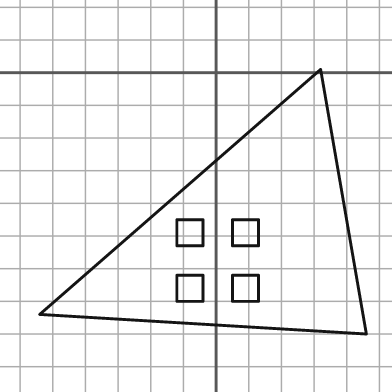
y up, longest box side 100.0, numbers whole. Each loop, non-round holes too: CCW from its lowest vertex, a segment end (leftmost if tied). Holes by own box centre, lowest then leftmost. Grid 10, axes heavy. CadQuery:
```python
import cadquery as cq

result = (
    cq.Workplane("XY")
    .moveTo(46.0, -80.0)
    .lineTo(32.0, 1.0)
    .lineTo(-54.0, -74.0)
    .close()
    .moveTo(-12.0, -70.0)
    .lineTo(-4.0, -70.0)
    .lineTo(-4.0, -62.0)
    .lineTo(-12.0, -62.0)
    .close()
    .moveTo(5.0, -70.0)
    .lineTo(13.0, -70.0)
    .lineTo(13.0, -62.0)
    .lineTo(5.0, -62.0)
    .close()
    .moveTo(-12.0, -53.0)
    .lineTo(-4.0, -53.0)
    .lineTo(-4.0, -45.0)
    .lineTo(-12.0, -45.0)
    .close()
    .moveTo(5.0, -53.0)
    .lineTo(13.0, -53.0)
    .lineTo(13.0, -45.0)
    .lineTo(5.0, -45.0)
    .close()
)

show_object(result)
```